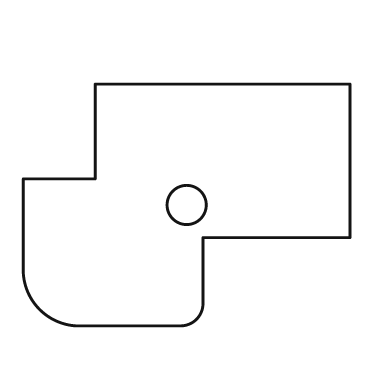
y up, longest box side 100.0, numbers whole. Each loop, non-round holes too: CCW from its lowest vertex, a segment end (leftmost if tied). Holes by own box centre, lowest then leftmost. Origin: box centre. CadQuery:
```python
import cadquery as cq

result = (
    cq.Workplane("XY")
    .moveTo(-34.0, -37.0)
    .lineTo(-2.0, -37.0)
    .threePointArc((3.0, -35.0), (5.0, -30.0))
    .lineTo(5.0, -10.0)
    .lineTo(50.0, -10.0)
    .lineTo(50.0, 37.0)
    .lineTo(-28.0, 37.0)
    .lineTo(-28.0, 8.0)
    .lineTo(-50.0, 8.0)
    .lineTo(-50.0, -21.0)
    .threePointArc((-45.0, -32.0), (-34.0, -37.0))
    .close()
    .moveTo(0.0, 0.0)
    .circle(6.0)
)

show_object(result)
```